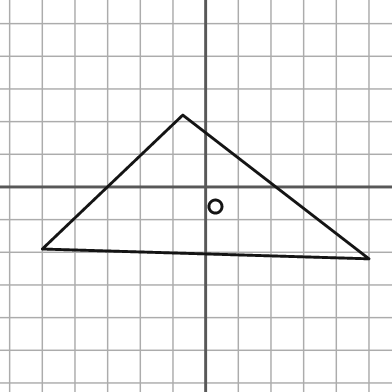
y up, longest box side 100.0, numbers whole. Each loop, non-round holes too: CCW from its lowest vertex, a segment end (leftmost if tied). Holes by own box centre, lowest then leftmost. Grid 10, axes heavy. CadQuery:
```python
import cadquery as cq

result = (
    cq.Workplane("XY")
    .moveTo(50.0, -22.0)
    .lineTo(-7.0, 22.0)
    .lineTo(-50.0, -19.0)
    .close()
    .moveTo(3.0, -6.0)
    .circle(2.0)
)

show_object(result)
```